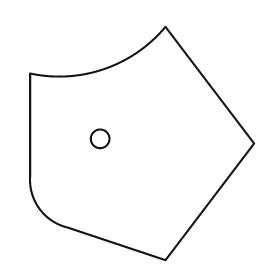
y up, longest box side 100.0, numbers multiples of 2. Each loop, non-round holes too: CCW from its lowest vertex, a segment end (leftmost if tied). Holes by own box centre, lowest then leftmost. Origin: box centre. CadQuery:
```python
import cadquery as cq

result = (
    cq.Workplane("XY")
    .moveTo(10.0, -50.0)
    .lineTo(48.0, 0.0)
    .lineTo(10.0, 50.0)
    .threePointArc((-16.0, 32.0), (-48.0, 30.0))
    .lineTo(-48.0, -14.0)
    .threePointArc((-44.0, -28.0), (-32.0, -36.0))
    .close()
    .moveTo(-18.0, 2.0)
    .circle(4.0)
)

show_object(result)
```